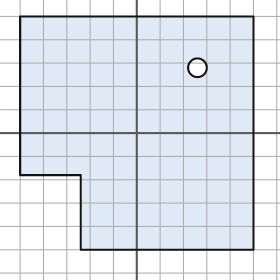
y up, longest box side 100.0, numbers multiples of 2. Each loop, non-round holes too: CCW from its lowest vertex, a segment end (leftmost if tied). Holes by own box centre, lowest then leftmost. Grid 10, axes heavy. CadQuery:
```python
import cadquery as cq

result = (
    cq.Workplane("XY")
    .moveTo(-24.0, -50.0)
    .lineTo(50.0, -50.0)
    .lineTo(50.0, 50.0)
    .lineTo(-50.0, 50.0)
    .lineTo(-50.0, -18.0)
    .lineTo(-24.0, -18.0)
    .close()
    .moveTo(26.0, 28.0)
    .circle(4.0)
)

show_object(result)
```